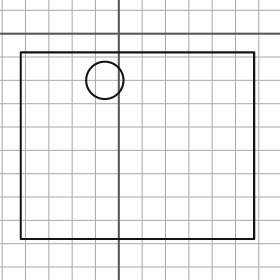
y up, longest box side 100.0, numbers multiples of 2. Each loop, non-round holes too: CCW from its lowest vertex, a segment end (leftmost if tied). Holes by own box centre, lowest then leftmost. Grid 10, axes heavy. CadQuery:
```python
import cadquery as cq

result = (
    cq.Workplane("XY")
    .moveTo(-42.0, -88.0)
    .lineTo(58.0, -88.0)
    .lineTo(58.0, -8.0)
    .lineTo(-42.0, -8.0)
    .close()
    .moveTo(-6.0, -20.0)
    .circle(8.0)
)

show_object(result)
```